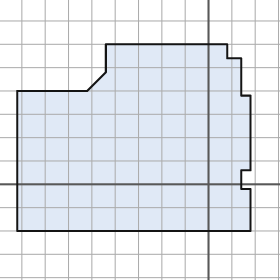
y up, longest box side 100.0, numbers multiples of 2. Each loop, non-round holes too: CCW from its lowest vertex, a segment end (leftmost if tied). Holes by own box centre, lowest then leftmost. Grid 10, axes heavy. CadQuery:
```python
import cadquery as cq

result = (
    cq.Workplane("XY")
    .moveTo(-82.0, -20.0)
    .lineTo(18.0, -20.0)
    .lineTo(18.0, -2.0)
    .lineTo(14.0, -2.0)
    .lineTo(14.0, 6.0)
    .lineTo(18.0, 6.0)
    .lineTo(18.0, 38.0)
    .lineTo(14.0, 38.0)
    .lineTo(14.0, 54.0)
    .lineTo(8.0, 54.0)
    .lineTo(8.0, 60.0)
    .lineTo(-44.0, 60.0)
    .lineTo(-44.0, 48.0)
    .lineTo(-52.0, 40.0)
    .lineTo(-82.0, 40.0)
    .close()
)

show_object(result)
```